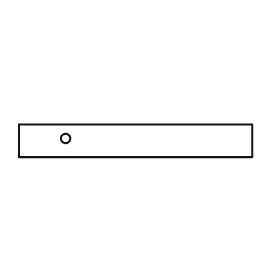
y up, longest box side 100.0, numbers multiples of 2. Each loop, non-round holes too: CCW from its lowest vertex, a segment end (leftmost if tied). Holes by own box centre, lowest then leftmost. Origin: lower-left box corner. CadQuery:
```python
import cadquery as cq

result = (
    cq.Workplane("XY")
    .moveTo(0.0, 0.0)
    .lineTo(100.0, 0.0)
    .lineTo(100.0, 14.0)
    .lineTo(0.0, 14.0)
    .close()
    .moveTo(20.0, 8.0)
    .circle(2.0)
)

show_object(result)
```